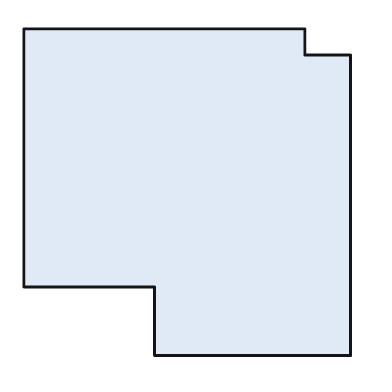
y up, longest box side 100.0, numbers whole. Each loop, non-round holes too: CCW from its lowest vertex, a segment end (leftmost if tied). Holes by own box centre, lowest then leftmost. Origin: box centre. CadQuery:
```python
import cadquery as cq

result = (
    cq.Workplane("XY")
    .moveTo(-10.0, -50.0)
    .lineTo(50.0, -50.0)
    .lineTo(50.0, 42.0)
    .lineTo(36.0, 42.0)
    .lineTo(36.0, 50.0)
    .lineTo(-50.0, 50.0)
    .lineTo(-50.0, -29.0)
    .lineTo(-10.0, -29.0)
    .close()
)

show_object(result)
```